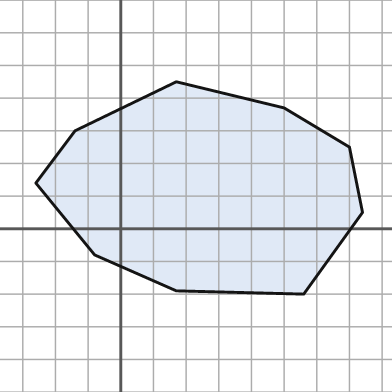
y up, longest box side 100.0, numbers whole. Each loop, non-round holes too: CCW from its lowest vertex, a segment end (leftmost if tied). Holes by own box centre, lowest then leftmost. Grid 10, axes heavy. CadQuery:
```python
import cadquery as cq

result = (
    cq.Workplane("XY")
    .moveTo(56.0, -20.0)
    .lineTo(74.0, 5.0)
    .lineTo(70.0, 25.0)
    .lineTo(50.0, 37.0)
    .lineTo(17.0, 45.0)
    .lineTo(-14.0, 30.0)
    .lineTo(-26.0, 14.0)
    .lineTo(-8.0, -8.0)
    .lineTo(17.0, -19.0)
    .close()
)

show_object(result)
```